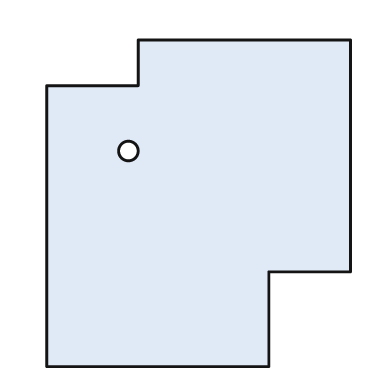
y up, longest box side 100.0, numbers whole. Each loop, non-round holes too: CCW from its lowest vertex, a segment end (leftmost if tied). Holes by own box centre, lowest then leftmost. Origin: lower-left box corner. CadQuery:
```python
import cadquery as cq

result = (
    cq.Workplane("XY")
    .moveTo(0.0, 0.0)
    .lineTo(68.0, 0.0)
    .lineTo(68.0, 29.0)
    .lineTo(93.0, 29.0)
    .lineTo(93.0, 100.0)
    .lineTo(28.0, 100.0)
    .lineTo(28.0, 86.0)
    .lineTo(0.0, 86.0)
    .close()
    .moveTo(25.0, 66.0)
    .circle(3.0)
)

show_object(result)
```